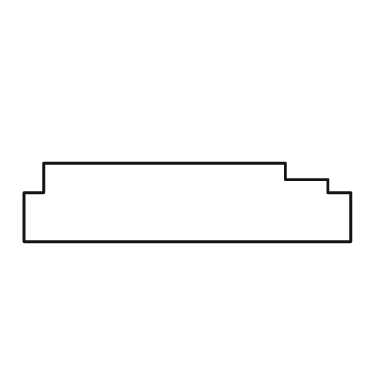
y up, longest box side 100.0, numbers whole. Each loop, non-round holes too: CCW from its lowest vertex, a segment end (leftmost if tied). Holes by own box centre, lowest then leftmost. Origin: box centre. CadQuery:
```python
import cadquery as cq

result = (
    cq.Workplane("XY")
    .moveTo(-50.0, -12.0)
    .lineTo(50.0, -12.0)
    .lineTo(50.0, 3.0)
    .lineTo(43.0, 3.0)
    .lineTo(43.0, 7.0)
    .lineTo(30.0, 7.0)
    .lineTo(30.0, 12.0)
    .lineTo(-44.0, 12.0)
    .lineTo(-44.0, 3.0)
    .lineTo(-50.0, 3.0)
    .close()
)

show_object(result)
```